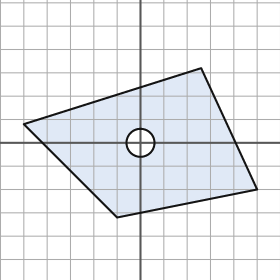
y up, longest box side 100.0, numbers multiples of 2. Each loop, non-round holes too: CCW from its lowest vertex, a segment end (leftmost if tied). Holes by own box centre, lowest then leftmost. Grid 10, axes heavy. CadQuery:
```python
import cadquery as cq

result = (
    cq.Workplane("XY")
    .moveTo(-10.0, -32.0)
    .lineTo(50.0, -20.0)
    .lineTo(26.0, 32.0)
    .lineTo(-50.0, 8.0)
    .close()
    .moveTo(0.0, 0.0)
    .circle(6.0)
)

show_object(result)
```